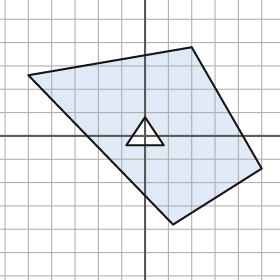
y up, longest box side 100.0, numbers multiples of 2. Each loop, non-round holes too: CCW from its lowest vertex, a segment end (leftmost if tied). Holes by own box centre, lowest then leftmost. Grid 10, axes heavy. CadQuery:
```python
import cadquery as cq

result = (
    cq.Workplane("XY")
    .moveTo(12.0, -38.0)
    .lineTo(50.0, -14.0)
    .lineTo(20.0, 38.0)
    .lineTo(-50.0, 26.0)
    .close()
    .moveTo(-8.0, -4.0)
    .lineTo(8.0, -4.0)
    .lineTo(0.0, 8.0)
    .close()
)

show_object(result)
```